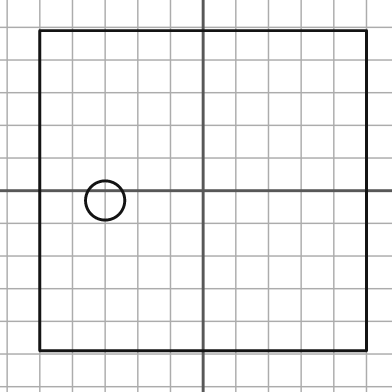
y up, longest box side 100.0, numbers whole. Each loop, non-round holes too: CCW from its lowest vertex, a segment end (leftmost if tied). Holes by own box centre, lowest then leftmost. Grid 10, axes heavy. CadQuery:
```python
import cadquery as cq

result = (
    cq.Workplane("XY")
    .moveTo(-50.0, -49.0)
    .lineTo(50.0, -49.0)
    .lineTo(50.0, 49.0)
    .lineTo(-50.0, 49.0)
    .close()
    .moveTo(-30.0, -3.0)
    .circle(6.0)
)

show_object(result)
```